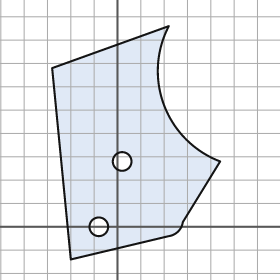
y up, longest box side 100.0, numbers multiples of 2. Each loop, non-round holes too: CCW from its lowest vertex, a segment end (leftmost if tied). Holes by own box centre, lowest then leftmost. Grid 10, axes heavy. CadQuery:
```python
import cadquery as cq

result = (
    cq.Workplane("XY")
    .moveTo(-20.0, -14.0)
    .lineTo(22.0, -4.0)
    .threePointArc((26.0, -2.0), (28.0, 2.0))
    .lineTo(44.0, 28.0)
    .threePointArc((20.0, 52.0), (22.0, 86.0))
    .lineTo(-28.0, 68.0)
    .close()
    .moveTo(-8.0, 0.0)
    .circle(4.0)
    .moveTo(2.0, 28.0)
    .circle(4.0)
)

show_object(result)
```